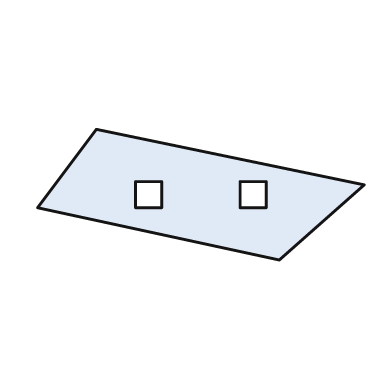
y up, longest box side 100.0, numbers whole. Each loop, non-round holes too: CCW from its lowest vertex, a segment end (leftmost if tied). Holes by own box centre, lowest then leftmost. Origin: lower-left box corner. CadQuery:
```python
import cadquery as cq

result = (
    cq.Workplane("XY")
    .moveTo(74.0, 0.0)
    .lineTo(100.0, 23.0)
    .lineTo(18.0, 40.0)
    .lineTo(0.0, 16.0)
    .close()
    .moveTo(30.0, 16.0)
    .lineTo(38.0, 16.0)
    .lineTo(38.0, 24.0)
    .lineTo(30.0, 24.0)
    .close()
    .moveTo(62.0, 16.0)
    .lineTo(70.0, 16.0)
    .lineTo(70.0, 24.0)
    .lineTo(62.0, 24.0)
    .close()
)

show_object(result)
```